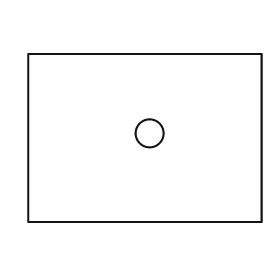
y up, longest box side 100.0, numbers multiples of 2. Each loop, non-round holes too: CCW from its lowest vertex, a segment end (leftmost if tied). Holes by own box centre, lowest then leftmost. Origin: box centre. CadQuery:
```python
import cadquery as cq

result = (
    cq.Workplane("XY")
    .moveTo(-50.0, -36.0)
    .lineTo(50.0, -36.0)
    .lineTo(50.0, 36.0)
    .lineTo(-50.0, 36.0)
    .close()
    .moveTo(2.0, 2.0)
    .circle(6.0)
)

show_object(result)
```